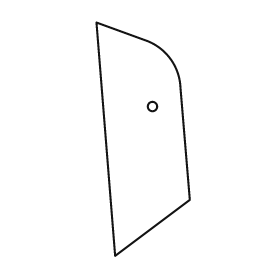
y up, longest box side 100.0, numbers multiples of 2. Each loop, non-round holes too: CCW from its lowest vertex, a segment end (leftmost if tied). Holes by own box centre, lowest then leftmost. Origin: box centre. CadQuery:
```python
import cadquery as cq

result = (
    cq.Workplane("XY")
    .moveTo(-12.0, -50.0)
    .lineTo(20.0, -26.0)
    .lineTo(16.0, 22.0)
    .threePointArc((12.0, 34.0), (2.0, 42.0))
    .lineTo(-20.0, 50.0)
    .close()
    .moveTo(4.0, 14.0)
    .circle(2.0)
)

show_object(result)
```